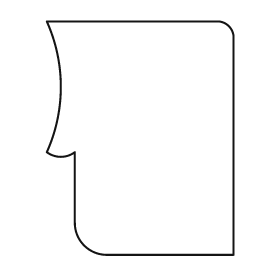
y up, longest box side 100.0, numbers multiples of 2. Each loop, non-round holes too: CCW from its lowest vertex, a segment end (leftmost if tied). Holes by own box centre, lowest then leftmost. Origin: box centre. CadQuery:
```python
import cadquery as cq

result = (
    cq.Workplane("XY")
    .moveTo(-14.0, -50.0)
    .lineTo(40.0, -50.0)
    .lineTo(40.0, 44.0)
    .threePointArc((38.0, 48.0), (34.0, 50.0))
    .lineTo(-40.0, 50.0)
    .threePointArc((-34.0, 22.0), (-40.0, -6.0))
    .threePointArc((-34.0, -8.0), (-28.0, -6.0))
    .lineTo(-28.0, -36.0)
    .threePointArc((-24.0, -46.0), (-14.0, -50.0))
    .close()
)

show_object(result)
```